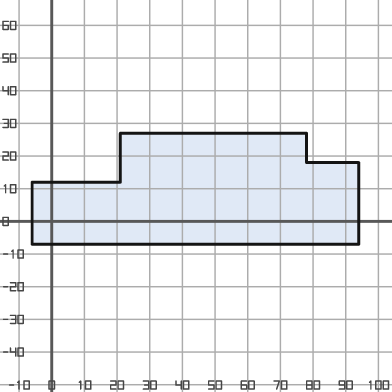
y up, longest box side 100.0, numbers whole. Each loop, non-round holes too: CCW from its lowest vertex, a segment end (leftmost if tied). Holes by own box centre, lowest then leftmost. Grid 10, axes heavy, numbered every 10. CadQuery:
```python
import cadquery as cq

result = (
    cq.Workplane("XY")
    .moveTo(-6.0, -7.0)
    .lineTo(94.0, -7.0)
    .lineTo(94.0, 18.0)
    .lineTo(78.0, 18.0)
    .lineTo(78.0, 27.0)
    .lineTo(21.0, 27.0)
    .lineTo(21.0, 12.0)
    .lineTo(-6.0, 12.0)
    .close()
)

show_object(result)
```